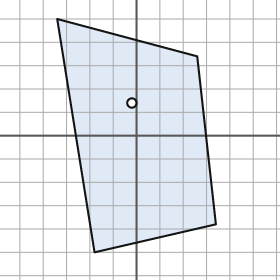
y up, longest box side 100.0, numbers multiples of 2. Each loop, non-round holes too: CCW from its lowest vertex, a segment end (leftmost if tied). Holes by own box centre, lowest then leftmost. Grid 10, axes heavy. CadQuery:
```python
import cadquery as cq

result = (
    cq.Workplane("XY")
    .moveTo(-18.0, -50.0)
    .lineTo(34.0, -38.0)
    .lineTo(26.0, 34.0)
    .lineTo(-34.0, 50.0)
    .close()
    .moveTo(-2.0, 14.0)
    .circle(2.0)
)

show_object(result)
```